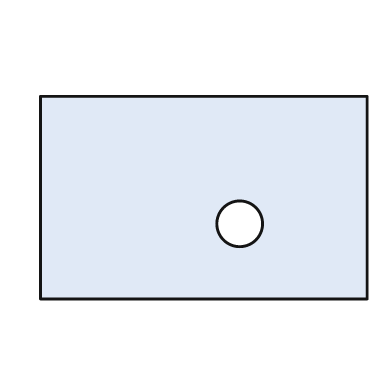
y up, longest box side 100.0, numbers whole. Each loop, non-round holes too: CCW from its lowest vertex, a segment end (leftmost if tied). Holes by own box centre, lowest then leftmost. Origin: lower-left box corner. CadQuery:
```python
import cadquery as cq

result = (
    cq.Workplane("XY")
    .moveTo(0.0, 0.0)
    .lineTo(100.0, 0.0)
    .lineTo(100.0, 62.0)
    .lineTo(0.0, 62.0)
    .close()
    .moveTo(61.0, 23.0)
    .circle(7.0)
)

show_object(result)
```